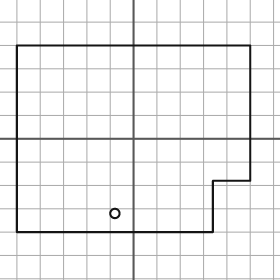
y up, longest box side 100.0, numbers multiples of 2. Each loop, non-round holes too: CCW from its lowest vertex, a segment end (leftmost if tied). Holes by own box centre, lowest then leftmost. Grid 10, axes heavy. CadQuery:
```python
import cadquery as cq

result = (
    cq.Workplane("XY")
    .moveTo(-50.0, -40.0)
    .lineTo(34.0, -40.0)
    .lineTo(34.0, -18.0)
    .lineTo(50.0, -18.0)
    .lineTo(50.0, 40.0)
    .lineTo(-50.0, 40.0)
    .close()
    .moveTo(-8.0, -32.0)
    .circle(2.0)
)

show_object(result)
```